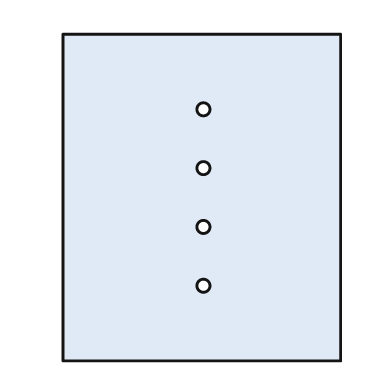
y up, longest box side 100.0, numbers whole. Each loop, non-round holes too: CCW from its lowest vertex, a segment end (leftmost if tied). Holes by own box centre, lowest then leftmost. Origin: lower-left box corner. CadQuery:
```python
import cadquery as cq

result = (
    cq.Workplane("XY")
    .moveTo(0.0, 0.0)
    .lineTo(85.0, 0.0)
    .lineTo(85.0, 100.0)
    .lineTo(0.0, 100.0)
    .close()
    .moveTo(43.0, 23.0)
    .circle(2.0)
    .moveTo(43.0, 41.0)
    .circle(2.0)
    .moveTo(43.0, 59.0)
    .circle(2.0)
    .moveTo(43.0, 77.0)
    .circle(2.0)
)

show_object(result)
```